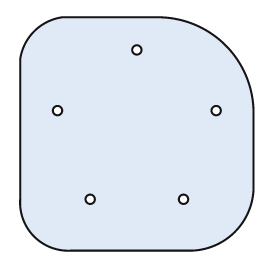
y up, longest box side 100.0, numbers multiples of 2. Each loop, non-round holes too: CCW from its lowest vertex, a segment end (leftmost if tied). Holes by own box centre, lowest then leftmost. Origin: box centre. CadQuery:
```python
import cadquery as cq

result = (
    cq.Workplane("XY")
    .moveTo(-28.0, -50.0)
    .lineTo(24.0, -50.0)
    .threePointArc((42.0, -42.0), (50.0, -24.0))
    .lineTo(50.0, 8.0)
    .threePointArc((38.0, 38.0), (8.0, 50.0))
    .lineTo(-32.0, 50.0)
    .threePointArc((-44.0, 44.0), (-50.0, 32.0))
    .lineTo(-50.0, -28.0)
    .threePointArc((-44.0, -44.0), (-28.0, -50.0))
    .close()
    .moveTo(-20.0, -28.0)
    .circle(2.0)
    .moveTo(20.0, -28.0)
    .circle(2.0)
    .moveTo(-34.0, 10.0)
    .circle(2.0)
    .moveTo(34.0, 10.0)
    .circle(2.0)
    .moveTo(0.0, 36.0)
    .circle(2.0)
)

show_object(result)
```